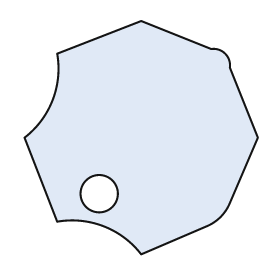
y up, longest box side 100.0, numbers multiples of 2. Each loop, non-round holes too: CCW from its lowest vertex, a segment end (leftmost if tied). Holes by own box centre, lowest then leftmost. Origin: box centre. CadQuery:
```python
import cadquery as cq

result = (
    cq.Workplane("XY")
    .moveTo(0.0, -50.0)
    .lineTo(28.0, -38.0)
    .threePointArc((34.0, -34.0), (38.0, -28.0))
    .lineTo(50.0, 0.0)
    .lineTo(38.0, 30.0)
    .threePointArc((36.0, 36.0), (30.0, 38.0))
    .lineTo(0.0, 50.0)
    .lineTo(-36.0, 36.0)
    .threePointArc((-38.0, 16.0), (-50.0, 0.0))
    .lineTo(-36.0, -36.0)
    .threePointArc((-16.0, -38.0), (0.0, -50.0))
    .close()
    .moveTo(-18.0, -24.0)
    .circle(8.0)
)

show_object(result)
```